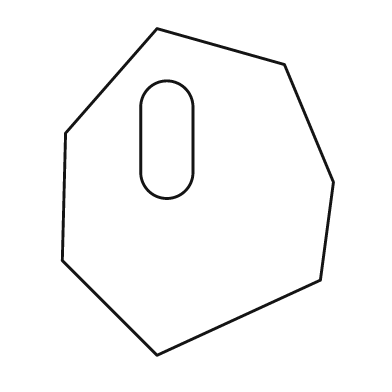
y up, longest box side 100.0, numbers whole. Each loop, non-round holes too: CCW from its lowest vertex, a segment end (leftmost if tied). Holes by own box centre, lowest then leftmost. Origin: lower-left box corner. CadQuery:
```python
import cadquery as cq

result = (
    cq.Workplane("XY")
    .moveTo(29.0, 0.0)
    .lineTo(79.0, 23.0)
    .lineTo(83.0, 53.0)
    .lineTo(68.0, 89.0)
    .lineTo(29.0, 100.0)
    .lineTo(1.0, 68.0)
    .lineTo(0.0, 29.0)
    .close()
    .moveTo(24.0, 56.0)
    .threePointArc((32.0, 48.0), (40.0, 56.0))
    .lineTo(40.0, 76.0)
    .threePointArc((32.0, 84.0), (24.0, 76.0))
    .close()
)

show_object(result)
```